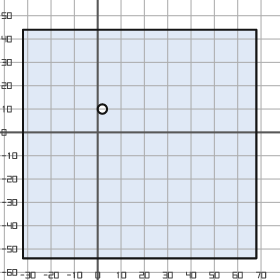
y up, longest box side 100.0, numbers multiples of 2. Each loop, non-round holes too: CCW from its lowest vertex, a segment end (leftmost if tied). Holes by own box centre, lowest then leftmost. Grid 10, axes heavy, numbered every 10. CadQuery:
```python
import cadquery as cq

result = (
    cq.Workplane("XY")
    .moveTo(-32.0, -54.0)
    .lineTo(68.0, -54.0)
    .lineTo(68.0, 44.0)
    .lineTo(-32.0, 44.0)
    .close()
    .moveTo(2.0, 10.0)
    .circle(2.0)
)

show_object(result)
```